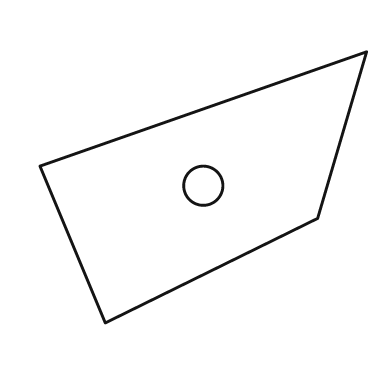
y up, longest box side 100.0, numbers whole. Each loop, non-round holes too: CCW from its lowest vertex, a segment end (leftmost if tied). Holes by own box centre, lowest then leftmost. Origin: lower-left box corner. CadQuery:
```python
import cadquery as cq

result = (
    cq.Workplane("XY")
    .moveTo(20.0, 0.0)
    .lineTo(85.0, 32.0)
    .lineTo(100.0, 83.0)
    .lineTo(0.0, 48.0)
    .close()
    .moveTo(50.0, 42.0)
    .circle(6.0)
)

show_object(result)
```